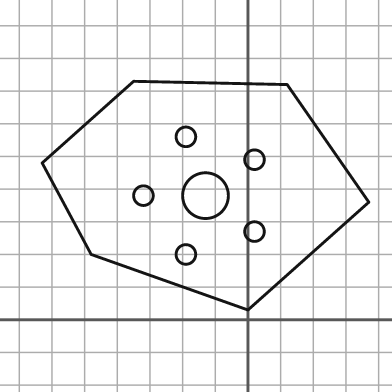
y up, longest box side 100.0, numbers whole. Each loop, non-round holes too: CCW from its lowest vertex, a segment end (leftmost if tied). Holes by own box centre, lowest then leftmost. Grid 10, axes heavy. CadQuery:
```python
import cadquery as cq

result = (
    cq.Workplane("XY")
    .moveTo(0.0, 3.0)
    .lineTo(37.0, 36.0)
    .lineTo(12.0, 72.0)
    .lineTo(-35.0, 73.0)
    .lineTo(-63.0, 48.0)
    .lineTo(-48.0, 20.0)
    .close()
    .moveTo(-19.0, 20.0)
    .circle(3.0)
    .moveTo(2.0, 27.0)
    .circle(3.0)
    .moveTo(-32.0, 38.0)
    .circle(3.0)
    .moveTo(-13.0, 38.0)
    .circle(7.0)
    .moveTo(2.0, 49.0)
    .circle(3.0)
    .moveTo(-19.0, 56.0)
    .circle(3.0)
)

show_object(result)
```